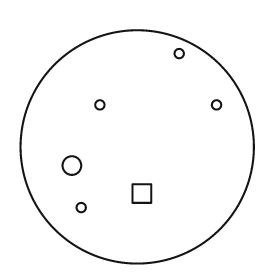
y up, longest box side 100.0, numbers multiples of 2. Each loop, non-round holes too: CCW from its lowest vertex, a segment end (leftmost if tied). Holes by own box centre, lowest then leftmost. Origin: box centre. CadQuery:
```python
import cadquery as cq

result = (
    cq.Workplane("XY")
    .moveTo(0.0, 0.0)
    .circle(50.0)
    .moveTo(-24.0, -26.0)
    .circle(2.0)
    .moveTo(-2.0, -24.0)
    .lineTo(6.0, -24.0)
    .lineTo(6.0, -16.0)
    .lineTo(-2.0, -16.0)
    .close()
    .moveTo(-28.0, -8.0)
    .circle(4.0)
    .moveTo(-16.0, 18.0)
    .circle(2.0)
    .moveTo(34.0, 18.0)
    .circle(2.0)
    .moveTo(18.0, 40.0)
    .circle(2.0)
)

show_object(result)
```